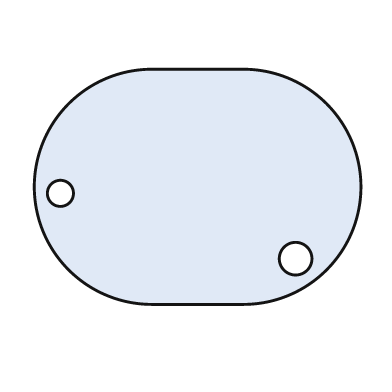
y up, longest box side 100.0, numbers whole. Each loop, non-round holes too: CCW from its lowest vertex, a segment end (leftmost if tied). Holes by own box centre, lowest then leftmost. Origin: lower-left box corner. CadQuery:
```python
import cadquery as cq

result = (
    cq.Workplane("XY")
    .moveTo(36.0, 0.0)
    .lineTo(64.0, 0.0)
    .threePointArc((100.0, 36.0), (64.0, 72.0))
    .lineTo(36.0, 72.0)
    .threePointArc((0.0, 36.0), (36.0, 0.0))
    .close()
    .moveTo(80.0, 14.0)
    .circle(5.0)
    .moveTo(8.0, 34.0)
    .circle(4.0)
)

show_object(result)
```